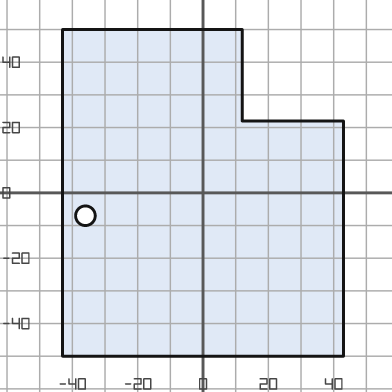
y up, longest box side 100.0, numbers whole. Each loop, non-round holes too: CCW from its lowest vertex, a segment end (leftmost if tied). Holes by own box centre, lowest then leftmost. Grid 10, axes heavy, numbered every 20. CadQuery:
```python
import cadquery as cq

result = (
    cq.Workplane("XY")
    .moveTo(-43.0, -50.0)
    .lineTo(43.0, -50.0)
    .lineTo(43.0, 22.0)
    .lineTo(12.0, 22.0)
    .lineTo(12.0, 50.0)
    .lineTo(-43.0, 50.0)
    .close()
    .moveTo(-36.0, -7.0)
    .circle(3.0)
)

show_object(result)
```